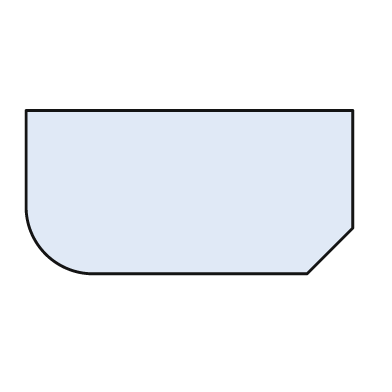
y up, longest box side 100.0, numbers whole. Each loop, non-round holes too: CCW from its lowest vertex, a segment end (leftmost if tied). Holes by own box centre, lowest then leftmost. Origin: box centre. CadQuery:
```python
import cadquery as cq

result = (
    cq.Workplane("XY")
    .moveTo(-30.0, -25.0)
    .lineTo(36.0, -25.0)
    .lineTo(50.0, -11.0)
    .lineTo(50.0, 25.0)
    .lineTo(-50.0, 25.0)
    .lineTo(-50.0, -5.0)
    .threePointArc((-44.0, -19.0), (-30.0, -25.0))
    .close()
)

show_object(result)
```